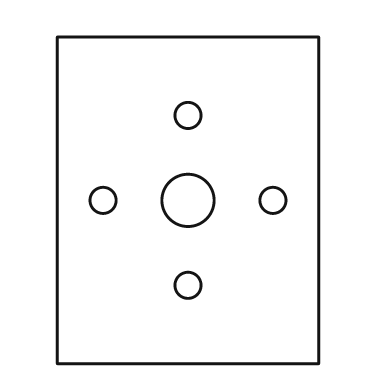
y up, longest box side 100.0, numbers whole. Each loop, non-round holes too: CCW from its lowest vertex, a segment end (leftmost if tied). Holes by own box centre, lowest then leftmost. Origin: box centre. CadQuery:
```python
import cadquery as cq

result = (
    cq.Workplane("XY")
    .moveTo(-40.0, -50.0)
    .lineTo(40.0, -50.0)
    .lineTo(40.0, 50.0)
    .lineTo(-40.0, 50.0)
    .close()
    .moveTo(0.0, -26.0)
    .circle(4.0)
    .moveTo(-26.0, 0.0)
    .circle(4.0)
    .moveTo(0.0, 0.0)
    .circle(8.0)
    .moveTo(26.0, 0.0)
    .circle(4.0)
    .moveTo(0.0, 26.0)
    .circle(4.0)
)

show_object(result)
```